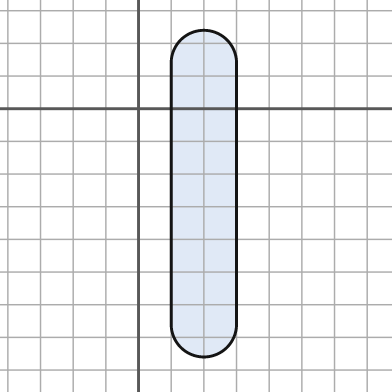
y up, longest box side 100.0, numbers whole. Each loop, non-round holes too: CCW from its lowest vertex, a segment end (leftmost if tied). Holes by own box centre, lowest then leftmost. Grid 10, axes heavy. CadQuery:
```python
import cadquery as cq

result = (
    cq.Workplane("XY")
    .moveTo(10.0, -66.0)
    .threePointArc((20.0, -76.0), (30.0, -66.0))
    .lineTo(30.0, 14.0)
    .threePointArc((20.0, 24.0), (10.0, 14.0))
    .close()
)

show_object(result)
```